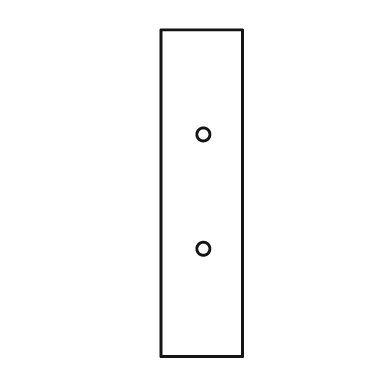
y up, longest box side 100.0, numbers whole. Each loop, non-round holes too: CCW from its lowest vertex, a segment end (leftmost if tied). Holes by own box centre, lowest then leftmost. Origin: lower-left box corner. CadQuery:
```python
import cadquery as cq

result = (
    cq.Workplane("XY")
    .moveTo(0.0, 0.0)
    .lineTo(25.0, 0.0)
    .lineTo(25.0, 100.0)
    .lineTo(0.0, 100.0)
    .close()
    .moveTo(13.0, 33.0)
    .circle(2.0)
    .moveTo(13.0, 68.0)
    .circle(2.0)
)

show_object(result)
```